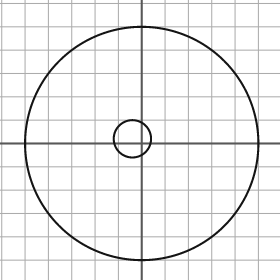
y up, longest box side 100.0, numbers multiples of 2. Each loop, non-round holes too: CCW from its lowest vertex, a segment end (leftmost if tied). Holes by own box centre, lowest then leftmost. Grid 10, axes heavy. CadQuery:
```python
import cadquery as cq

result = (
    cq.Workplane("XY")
    .moveTo(0.0, 0.0)
    .circle(50.0)
    .moveTo(-4.0, 2.0)
    .circle(8.0)
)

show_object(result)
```